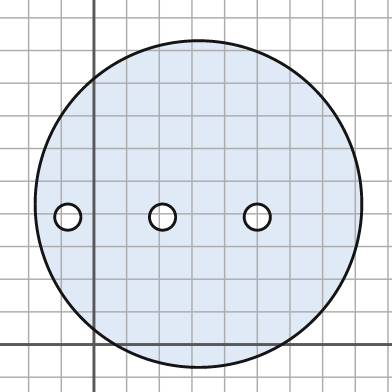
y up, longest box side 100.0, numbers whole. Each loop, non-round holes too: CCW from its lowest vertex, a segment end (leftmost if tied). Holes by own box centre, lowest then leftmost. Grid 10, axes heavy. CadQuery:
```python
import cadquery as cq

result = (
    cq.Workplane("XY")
    .moveTo(32.0, 43.0)
    .circle(50.0)
    .moveTo(-8.0, 39.0)
    .circle(4.0)
    .moveTo(21.0, 39.0)
    .circle(4.0)
    .moveTo(50.0, 39.0)
    .circle(4.0)
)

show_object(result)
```